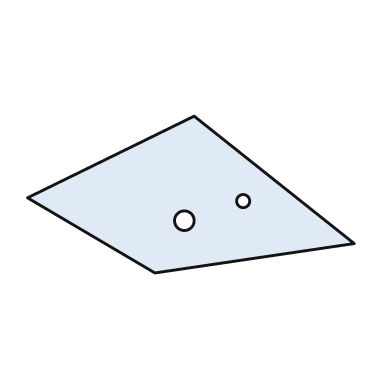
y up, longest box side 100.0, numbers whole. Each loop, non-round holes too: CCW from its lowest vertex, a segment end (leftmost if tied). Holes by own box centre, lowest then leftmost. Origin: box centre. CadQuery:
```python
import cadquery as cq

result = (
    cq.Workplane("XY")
    .moveTo(-11.0, -24.0)
    .lineTo(50.0, -15.0)
    .lineTo(1.0, 24.0)
    .lineTo(-50.0, -1.0)
    .close()
    .moveTo(-2.0, -8.0)
    .circle(3.0)
    .moveTo(16.0, -2.0)
    .circle(2.0)
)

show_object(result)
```